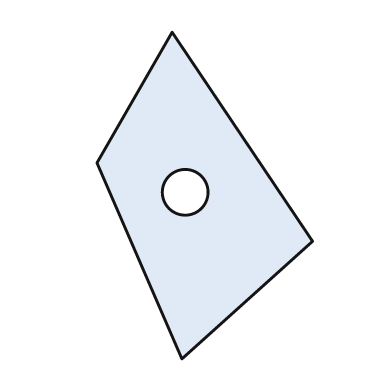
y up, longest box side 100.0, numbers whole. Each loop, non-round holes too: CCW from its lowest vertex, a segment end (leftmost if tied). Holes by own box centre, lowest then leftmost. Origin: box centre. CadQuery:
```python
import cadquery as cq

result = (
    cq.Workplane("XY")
    .moveTo(-7.0, -50.0)
    .lineTo(33.0, -14.0)
    .lineTo(-10.0, 50.0)
    .lineTo(-33.0, 10.0)
    .close()
    .moveTo(-6.0, 1.0)
    .circle(7.0)
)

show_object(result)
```